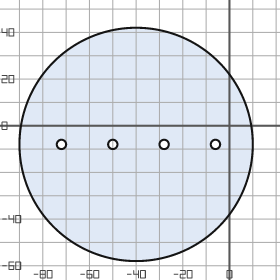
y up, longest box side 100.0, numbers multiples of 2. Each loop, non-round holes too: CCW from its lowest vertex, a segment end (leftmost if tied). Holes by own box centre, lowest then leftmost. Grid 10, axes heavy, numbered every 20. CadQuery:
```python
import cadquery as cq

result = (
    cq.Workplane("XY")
    .moveTo(-40.0, -8.0)
    .circle(50.0)
    .moveTo(-72.0, -8.0)
    .circle(2.0)
    .moveTo(-50.0, -8.0)
    .circle(2.0)
    .moveTo(-28.0, -8.0)
    .circle(2.0)
    .moveTo(-6.0, -8.0)
    .circle(2.0)
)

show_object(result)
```